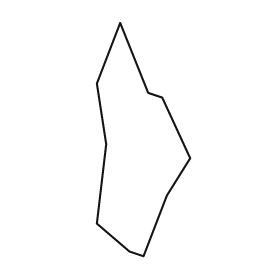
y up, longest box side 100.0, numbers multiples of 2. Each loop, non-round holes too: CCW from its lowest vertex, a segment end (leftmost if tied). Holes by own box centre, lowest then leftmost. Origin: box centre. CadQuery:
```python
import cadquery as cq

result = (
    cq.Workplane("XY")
    .moveTo(0.0, -50.0)
    .lineTo(10.0, -24.0)
    .lineTo(20.0, -8.0)
    .lineTo(8.0, 18.0)
    .lineTo(2.0, 20.0)
    .lineTo(-10.0, 50.0)
    .lineTo(-20.0, 24.0)
    .lineTo(-16.0, -2.0)
    .lineTo(-20.0, -36.0)
    .lineTo(-6.0, -48.0)
    .close()
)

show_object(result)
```